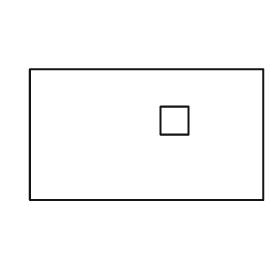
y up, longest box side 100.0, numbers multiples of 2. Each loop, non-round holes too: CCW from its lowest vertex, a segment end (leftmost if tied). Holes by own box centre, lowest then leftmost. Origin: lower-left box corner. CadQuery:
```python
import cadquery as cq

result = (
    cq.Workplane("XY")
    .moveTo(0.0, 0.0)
    .lineTo(100.0, 0.0)
    .lineTo(100.0, 56.0)
    .lineTo(0.0, 56.0)
    .close()
    .moveTo(56.0, 28.0)
    .lineTo(68.0, 28.0)
    .lineTo(68.0, 40.0)
    .lineTo(56.0, 40.0)
    .close()
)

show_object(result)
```